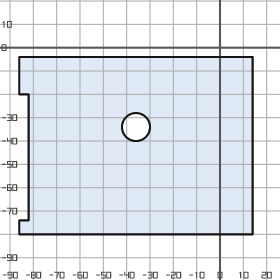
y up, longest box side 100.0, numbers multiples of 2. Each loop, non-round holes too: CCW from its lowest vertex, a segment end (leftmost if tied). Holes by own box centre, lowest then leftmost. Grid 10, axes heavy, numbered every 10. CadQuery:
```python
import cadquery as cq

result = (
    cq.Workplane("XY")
    .moveTo(-86.0, -80.0)
    .lineTo(14.0, -80.0)
    .lineTo(14.0, -4.0)
    .lineTo(-86.0, -4.0)
    .lineTo(-86.0, -20.0)
    .lineTo(-82.0, -20.0)
    .lineTo(-82.0, -74.0)
    .lineTo(-86.0, -74.0)
    .close()
    .moveTo(-36.0, -34.0)
    .circle(6.0)
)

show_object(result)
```